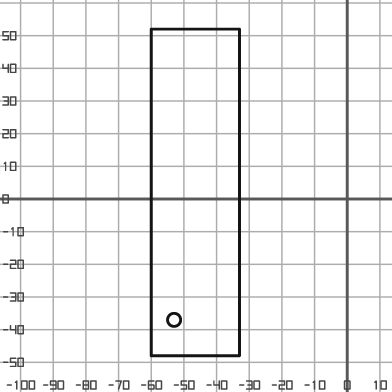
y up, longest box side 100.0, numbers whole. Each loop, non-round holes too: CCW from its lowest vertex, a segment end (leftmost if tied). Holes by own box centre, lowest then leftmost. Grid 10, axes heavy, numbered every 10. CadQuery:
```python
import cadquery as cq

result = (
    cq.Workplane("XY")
    .moveTo(-60.0, -48.0)
    .lineTo(-33.0, -48.0)
    .lineTo(-33.0, 52.0)
    .lineTo(-60.0, 52.0)
    .close()
    .moveTo(-53.0, -37.0)
    .circle(2.0)
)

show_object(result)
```